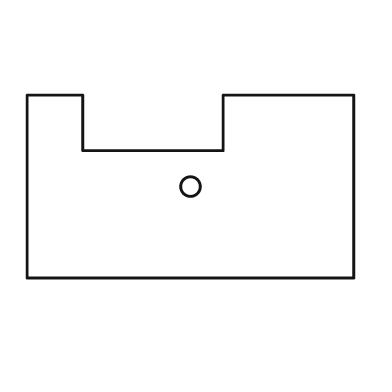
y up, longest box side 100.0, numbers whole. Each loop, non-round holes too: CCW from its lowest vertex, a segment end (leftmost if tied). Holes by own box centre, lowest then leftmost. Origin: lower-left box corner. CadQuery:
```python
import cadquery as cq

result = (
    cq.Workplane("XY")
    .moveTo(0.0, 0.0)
    .lineTo(100.0, 0.0)
    .lineTo(100.0, 56.0)
    .lineTo(60.0, 56.0)
    .lineTo(60.0, 39.0)
    .lineTo(17.0, 39.0)
    .lineTo(17.0, 56.0)
    .lineTo(0.0, 56.0)
    .close()
    .moveTo(50.0, 28.0)
    .circle(3.0)
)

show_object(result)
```